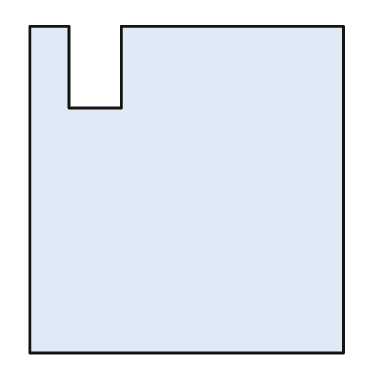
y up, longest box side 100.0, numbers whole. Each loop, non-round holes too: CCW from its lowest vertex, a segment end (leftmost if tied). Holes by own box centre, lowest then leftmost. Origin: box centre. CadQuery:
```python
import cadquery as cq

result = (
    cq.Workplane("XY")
    .moveTo(-48.0, -50.0)
    .lineTo(48.0, -50.0)
    .lineTo(48.0, 50.0)
    .lineTo(-20.0, 50.0)
    .lineTo(-20.0, 25.0)
    .lineTo(-36.0, 25.0)
    .lineTo(-36.0, 50.0)
    .lineTo(-48.0, 50.0)
    .close()
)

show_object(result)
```